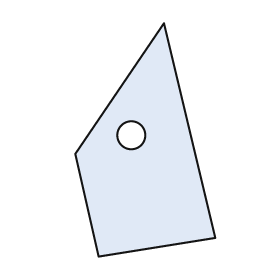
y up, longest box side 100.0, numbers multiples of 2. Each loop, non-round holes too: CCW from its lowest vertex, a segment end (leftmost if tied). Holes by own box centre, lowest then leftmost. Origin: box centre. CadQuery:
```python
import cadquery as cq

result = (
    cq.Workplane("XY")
    .moveTo(-20.0, -50.0)
    .lineTo(30.0, -42.0)
    .lineTo(8.0, 50.0)
    .lineTo(-30.0, -6.0)
    .close()
    .moveTo(-6.0, 2.0)
    .circle(6.0)
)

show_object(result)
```